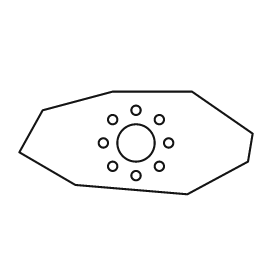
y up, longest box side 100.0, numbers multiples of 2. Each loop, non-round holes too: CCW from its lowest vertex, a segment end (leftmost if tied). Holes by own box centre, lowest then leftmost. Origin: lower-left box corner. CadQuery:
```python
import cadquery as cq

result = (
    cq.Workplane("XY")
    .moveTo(72.0, 0.0)
    .lineTo(98.0, 14.0)
    .lineTo(100.0, 26.0)
    .lineTo(74.0, 44.0)
    .lineTo(40.0, 44.0)
    .lineTo(10.0, 36.0)
    .lineTo(0.0, 18.0)
    .lineTo(24.0, 4.0)
    .close()
    .moveTo(50.0, 8.0)
    .circle(2.0)
    .moveTo(40.0, 12.0)
    .circle(2.0)
    .moveTo(60.0, 12.0)
    .circle(2.0)
    .moveTo(36.0, 22.0)
    .circle(2.0)
    .moveTo(50.0, 22.0)
    .circle(8.0)
    .moveTo(64.0, 22.0)
    .circle(2.0)
    .moveTo(40.0, 32.0)
    .circle(2.0)
    .moveTo(60.0, 32.0)
    .circle(2.0)
    .moveTo(50.0, 36.0)
    .circle(2.0)
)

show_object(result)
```